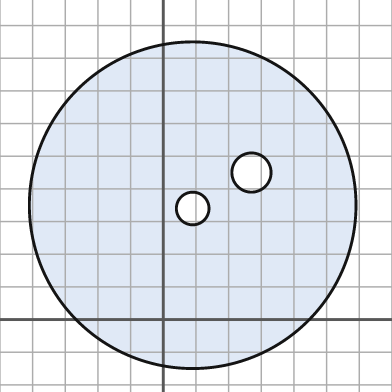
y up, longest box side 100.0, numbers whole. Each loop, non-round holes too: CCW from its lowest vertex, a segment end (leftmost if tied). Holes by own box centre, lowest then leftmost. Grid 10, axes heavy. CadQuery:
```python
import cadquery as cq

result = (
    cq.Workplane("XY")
    .moveTo(9.0, 35.0)
    .circle(50.0)
    .moveTo(9.0, 34.0)
    .circle(5.0)
    .moveTo(27.0, 45.0)
    .circle(6.0)
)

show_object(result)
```